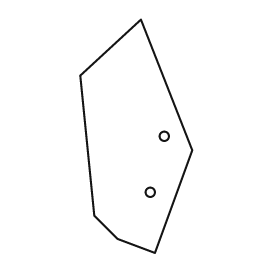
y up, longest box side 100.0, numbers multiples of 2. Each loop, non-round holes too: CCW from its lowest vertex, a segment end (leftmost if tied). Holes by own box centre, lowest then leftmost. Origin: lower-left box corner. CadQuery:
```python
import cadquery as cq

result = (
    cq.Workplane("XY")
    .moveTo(32.0, 0.0)
    .lineTo(48.0, 44.0)
    .lineTo(26.0, 100.0)
    .lineTo(0.0, 76.0)
    .lineTo(6.0, 16.0)
    .lineTo(16.0, 6.0)
    .close()
    .moveTo(30.0, 26.0)
    .circle(2.0)
    .moveTo(36.0, 50.0)
    .circle(2.0)
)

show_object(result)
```